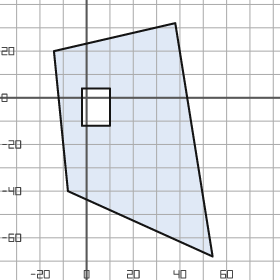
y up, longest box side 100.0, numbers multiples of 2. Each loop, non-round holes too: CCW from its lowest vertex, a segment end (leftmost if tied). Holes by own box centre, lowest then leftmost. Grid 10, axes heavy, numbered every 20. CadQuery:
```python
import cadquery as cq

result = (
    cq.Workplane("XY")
    .moveTo(54.0, -68.0)
    .lineTo(38.0, 32.0)
    .lineTo(-14.0, 20.0)
    .lineTo(-8.0, -40.0)
    .close()
    .moveTo(-2.0, -12.0)
    .lineTo(10.0, -12.0)
    .lineTo(10.0, 4.0)
    .lineTo(-2.0, 4.0)
    .close()
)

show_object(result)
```